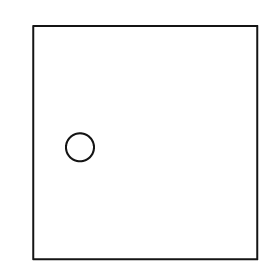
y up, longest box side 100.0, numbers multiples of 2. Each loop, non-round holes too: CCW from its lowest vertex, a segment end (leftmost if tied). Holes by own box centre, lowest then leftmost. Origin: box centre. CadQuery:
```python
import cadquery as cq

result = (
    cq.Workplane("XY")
    .moveTo(-48.0, -50.0)
    .lineTo(48.0, -50.0)
    .lineTo(48.0, 50.0)
    .lineTo(-48.0, 50.0)
    .close()
    .moveTo(-28.0, -2.0)
    .circle(6.0)
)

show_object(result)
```